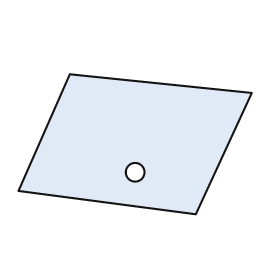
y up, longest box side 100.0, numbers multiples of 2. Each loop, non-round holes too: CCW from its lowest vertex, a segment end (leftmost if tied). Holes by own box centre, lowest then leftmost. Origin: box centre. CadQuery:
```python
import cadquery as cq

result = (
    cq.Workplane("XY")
    .moveTo(26.0, -30.0)
    .lineTo(50.0, 22.0)
    .lineTo(-28.0, 30.0)
    .lineTo(-50.0, -20.0)
    .close()
    .moveTo(0.0, -12.0)
    .circle(4.0)
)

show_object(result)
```